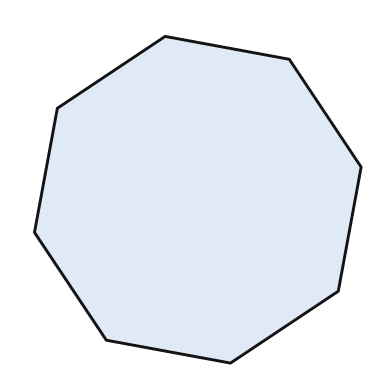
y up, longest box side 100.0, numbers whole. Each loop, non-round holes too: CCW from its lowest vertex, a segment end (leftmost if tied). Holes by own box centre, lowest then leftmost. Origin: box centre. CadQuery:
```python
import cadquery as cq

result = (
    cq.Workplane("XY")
    .moveTo(10.0, -50.0)
    .lineTo(43.0, -28.0)
    .lineTo(50.0, 10.0)
    .lineTo(28.0, 43.0)
    .lineTo(-10.0, 50.0)
    .lineTo(-43.0, 28.0)
    .lineTo(-50.0, -10.0)
    .lineTo(-28.0, -43.0)
    .close()
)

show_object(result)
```